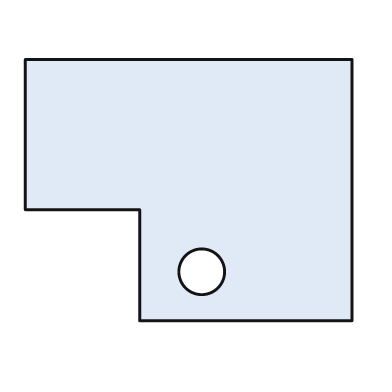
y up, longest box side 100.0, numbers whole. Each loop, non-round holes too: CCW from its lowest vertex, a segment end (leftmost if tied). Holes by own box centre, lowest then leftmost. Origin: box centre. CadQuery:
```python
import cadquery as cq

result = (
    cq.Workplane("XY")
    .moveTo(-15.0, -40.0)
    .lineTo(50.0, -40.0)
    .lineTo(50.0, 40.0)
    .lineTo(-50.0, 40.0)
    .lineTo(-50.0, -6.0)
    .lineTo(-15.0, -6.0)
    .close()
    .moveTo(4.0, -25.0)
    .circle(7.0)
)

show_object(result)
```